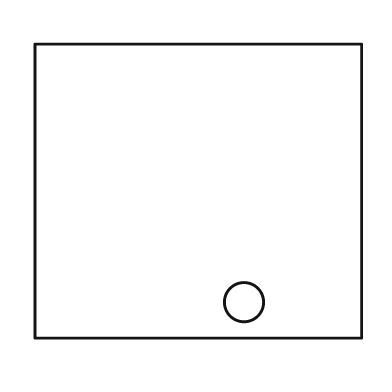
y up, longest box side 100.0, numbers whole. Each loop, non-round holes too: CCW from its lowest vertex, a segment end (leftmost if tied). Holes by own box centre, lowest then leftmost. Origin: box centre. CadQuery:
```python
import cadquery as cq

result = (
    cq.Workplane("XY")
    .moveTo(-50.0, -45.0)
    .lineTo(50.0, -45.0)
    .lineTo(50.0, 45.0)
    .lineTo(-50.0, 45.0)
    .close()
    .moveTo(14.0, -34.0)
    .circle(6.0)
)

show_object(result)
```